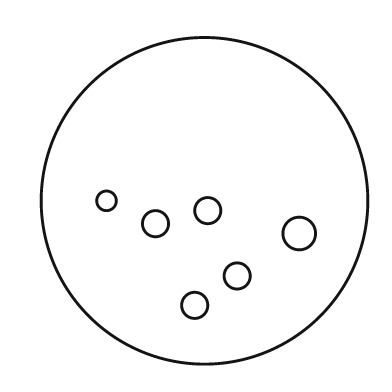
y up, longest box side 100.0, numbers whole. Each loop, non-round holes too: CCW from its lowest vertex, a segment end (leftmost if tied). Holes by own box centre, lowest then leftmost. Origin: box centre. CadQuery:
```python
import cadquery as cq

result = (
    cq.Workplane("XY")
    .moveTo(0.0, 0.0)
    .circle(50.0)
    .moveTo(-3.0, -32.0)
    .circle(4.0)
    .moveTo(10.0, -23.0)
    .circle(4.0)
    .moveTo(29.0, -10.0)
    .circle(5.0)
    .moveTo(-15.0, -7.0)
    .circle(4.0)
    .moveTo(1.0, -3.0)
    .circle(4.0)
    .moveTo(-30.0, 0.0)
    .circle(3.0)
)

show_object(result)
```